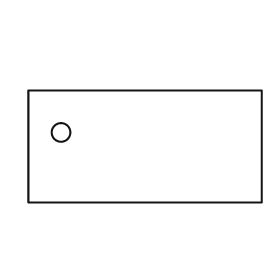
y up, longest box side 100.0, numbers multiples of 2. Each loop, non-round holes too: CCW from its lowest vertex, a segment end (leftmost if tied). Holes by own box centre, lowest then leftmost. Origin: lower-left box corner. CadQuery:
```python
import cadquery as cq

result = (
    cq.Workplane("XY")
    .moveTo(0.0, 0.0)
    .lineTo(100.0, 0.0)
    .lineTo(100.0, 48.0)
    .lineTo(0.0, 48.0)
    .close()
    .moveTo(14.0, 30.0)
    .circle(4.0)
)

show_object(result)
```